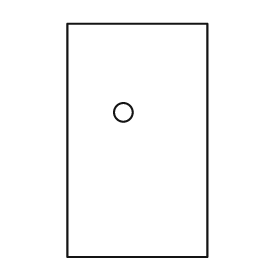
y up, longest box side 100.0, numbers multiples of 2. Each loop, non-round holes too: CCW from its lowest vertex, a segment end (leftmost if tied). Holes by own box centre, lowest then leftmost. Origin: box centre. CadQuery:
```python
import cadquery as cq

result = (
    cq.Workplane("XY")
    .moveTo(-30.0, -50.0)
    .lineTo(30.0, -50.0)
    .lineTo(30.0, 50.0)
    .lineTo(-30.0, 50.0)
    .close()
    .moveTo(-6.0, 12.0)
    .circle(4.0)
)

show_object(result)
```